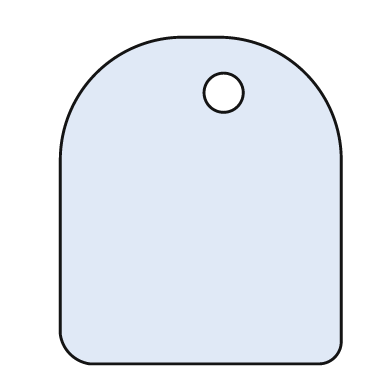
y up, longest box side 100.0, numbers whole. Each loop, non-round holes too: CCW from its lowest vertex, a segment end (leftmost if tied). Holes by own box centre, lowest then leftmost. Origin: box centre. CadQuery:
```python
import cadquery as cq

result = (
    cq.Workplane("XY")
    .moveTo(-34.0, -50.0)
    .lineTo(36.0, -50.0)
    .threePointArc((41.0, -48.0), (43.0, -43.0))
    .lineTo(43.0, 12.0)
    .threePointArc((32.0, 39.0), (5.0, 50.0))
    .lineTo(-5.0, 50.0)
    .threePointArc((-32.0, 39.0), (-43.0, 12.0))
    .lineTo(-43.0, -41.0)
    .threePointArc((-40.0, -47.0), (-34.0, -50.0))
    .close()
    .moveTo(7.0, 33.0)
    .circle(6.0)
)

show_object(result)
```